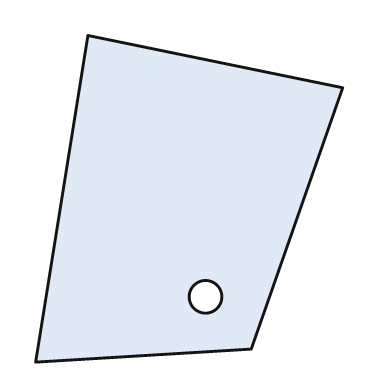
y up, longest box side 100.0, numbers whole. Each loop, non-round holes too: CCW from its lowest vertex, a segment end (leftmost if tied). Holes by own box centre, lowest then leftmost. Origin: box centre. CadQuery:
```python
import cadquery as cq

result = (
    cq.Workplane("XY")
    .moveTo(-47.0, -50.0)
    .lineTo(19.0, -46.0)
    .lineTo(47.0, 34.0)
    .lineTo(-31.0, 50.0)
    .close()
    .moveTo(5.0, -30.0)
    .circle(5.0)
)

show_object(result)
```